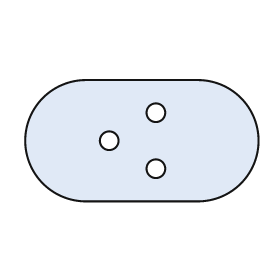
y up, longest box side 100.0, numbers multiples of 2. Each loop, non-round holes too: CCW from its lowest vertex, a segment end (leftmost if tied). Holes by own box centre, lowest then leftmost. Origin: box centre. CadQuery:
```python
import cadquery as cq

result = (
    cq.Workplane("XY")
    .moveTo(-24.0, -26.0)
    .lineTo(24.0, -26.0)
    .threePointArc((50.0, 0.0), (24.0, 26.0))
    .lineTo(-24.0, 26.0)
    .threePointArc((-50.0, 0.0), (-24.0, -26.0))
    .close()
    .moveTo(6.0, -12.0)
    .circle(4.0)
    .moveTo(-14.0, 0.0)
    .circle(4.0)
    .moveTo(6.0, 12.0)
    .circle(4.0)
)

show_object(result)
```